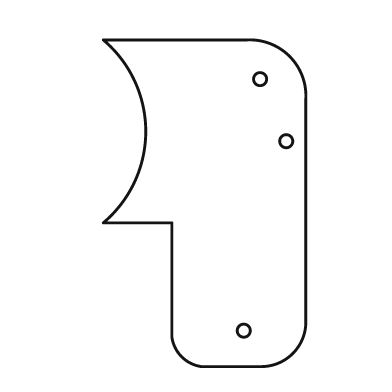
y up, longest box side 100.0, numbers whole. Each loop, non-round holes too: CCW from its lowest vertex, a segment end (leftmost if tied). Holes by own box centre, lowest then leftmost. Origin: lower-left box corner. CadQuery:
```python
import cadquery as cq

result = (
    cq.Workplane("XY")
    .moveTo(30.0, 0.0)
    .lineTo(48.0, 0.0)
    .threePointArc((58.0, 4.0), (62.0, 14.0))
    .lineTo(62.0, 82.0)
    .threePointArc((57.0, 95.0), (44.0, 100.0))
    .lineTo(0.0, 100.0)
    .threePointArc((13.0, 72.0), (0.0, 44.0))
    .lineTo(21.0, 44.0)
    .lineTo(21.0, 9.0)
    .threePointArc((24.0, 3.0), (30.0, 0.0))
    .close()
    .moveTo(43.0, 11.0)
    .circle(2.0)
    .moveTo(56.0, 69.0)
    .circle(2.0)
    .moveTo(48.0, 88.0)
    .circle(2.0)
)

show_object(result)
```